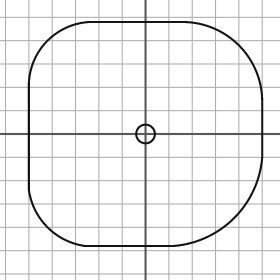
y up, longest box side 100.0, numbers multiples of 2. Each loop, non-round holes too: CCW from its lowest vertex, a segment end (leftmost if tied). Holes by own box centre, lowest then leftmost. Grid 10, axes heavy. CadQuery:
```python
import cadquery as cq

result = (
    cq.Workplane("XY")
    .moveTo(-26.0, -48.0)
    .lineTo(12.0, -48.0)
    .threePointArc((38.0, -36.0), (50.0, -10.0))
    .lineTo(50.0, 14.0)
    .threePointArc((40.0, 38.0), (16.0, 48.0))
    .lineTo(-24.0, 48.0)
    .threePointArc((-42.0, 40.0), (-50.0, 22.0))
    .lineTo(-50.0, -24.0)
    .threePointArc((-42.0, -40.0), (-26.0, -48.0))
    .close()
    .moveTo(0.0, 0.0)
    .circle(4.0)
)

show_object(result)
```